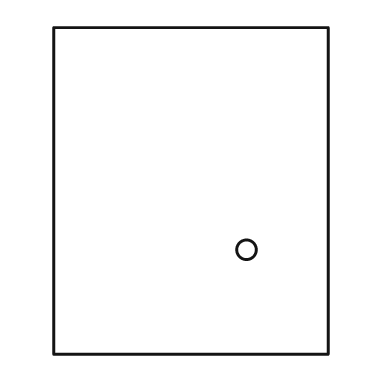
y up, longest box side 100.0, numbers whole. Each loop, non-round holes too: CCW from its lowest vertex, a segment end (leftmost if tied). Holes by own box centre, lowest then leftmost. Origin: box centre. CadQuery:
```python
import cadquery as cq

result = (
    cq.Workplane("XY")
    .moveTo(-42.0, -50.0)
    .lineTo(42.0, -50.0)
    .lineTo(42.0, 50.0)
    .lineTo(-42.0, 50.0)
    .close()
    .moveTo(17.0, -18.0)
    .circle(3.0)
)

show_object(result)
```